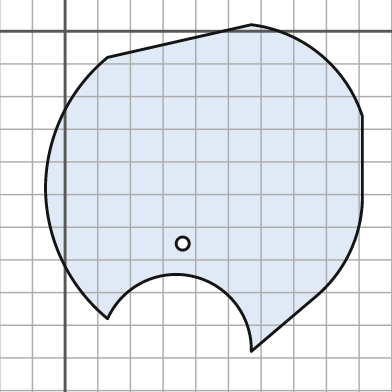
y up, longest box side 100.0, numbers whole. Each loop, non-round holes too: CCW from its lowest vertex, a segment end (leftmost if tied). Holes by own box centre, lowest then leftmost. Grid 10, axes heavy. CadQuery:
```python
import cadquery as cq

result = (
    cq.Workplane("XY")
    .moveTo(57.0, -98.0)
    .lineTo(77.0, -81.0)
    .threePointArc((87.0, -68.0), (91.0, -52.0))
    .lineTo(91.0, -26.0)
    .threePointArc((78.0, -7.0), (57.0, 2.0))
    .lineTo(13.0, -8.0)
    .threePointArc((-1.0, -26.0), (-6.0, -48.0))
    .threePointArc((-1.0, -70.0), (13.0, -88.0))
    .threePointArc((39.0, -75.0), (57.0, -98.0))
    .close()
    .moveTo(36.0, -65.0)
    .circle(2.0)
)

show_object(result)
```